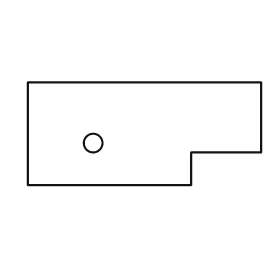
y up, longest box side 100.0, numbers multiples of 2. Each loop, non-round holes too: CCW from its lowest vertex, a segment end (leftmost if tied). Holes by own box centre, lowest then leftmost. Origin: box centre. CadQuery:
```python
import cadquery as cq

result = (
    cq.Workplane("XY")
    .moveTo(-50.0, -22.0)
    .lineTo(20.0, -22.0)
    .lineTo(20.0, -8.0)
    .lineTo(50.0, -8.0)
    .lineTo(50.0, 22.0)
    .lineTo(-50.0, 22.0)
    .close()
    .moveTo(-22.0, -4.0)
    .circle(4.0)
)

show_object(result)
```